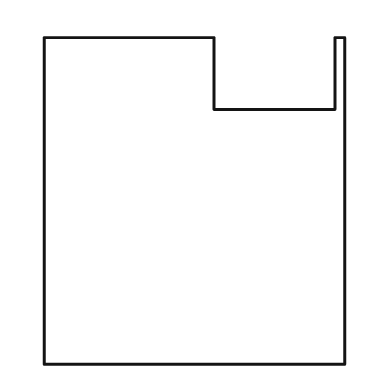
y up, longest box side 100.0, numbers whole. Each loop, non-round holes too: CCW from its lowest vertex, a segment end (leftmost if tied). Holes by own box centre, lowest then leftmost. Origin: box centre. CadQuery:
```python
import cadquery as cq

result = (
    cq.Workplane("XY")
    .moveTo(-46.0, -50.0)
    .lineTo(46.0, -50.0)
    .lineTo(46.0, 50.0)
    .lineTo(43.0, 50.0)
    .lineTo(43.0, 28.0)
    .lineTo(6.0, 28.0)
    .lineTo(6.0, 50.0)
    .lineTo(-46.0, 50.0)
    .close()
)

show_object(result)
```